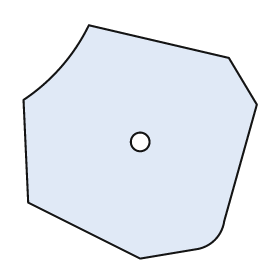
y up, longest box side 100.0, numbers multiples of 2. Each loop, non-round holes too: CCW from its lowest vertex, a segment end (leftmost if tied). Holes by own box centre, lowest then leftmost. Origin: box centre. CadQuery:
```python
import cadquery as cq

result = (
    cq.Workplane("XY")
    .moveTo(0.0, -50.0)
    .lineTo(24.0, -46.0)
    .threePointArc((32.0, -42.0), (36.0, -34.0))
    .lineTo(50.0, 16.0)
    .lineTo(38.0, 36.0)
    .lineTo(-22.0, 50.0)
    .threePointArc((-34.0, 32.0), (-50.0, 18.0))
    .lineTo(-48.0, -26.0)
    .close()
    .moveTo(0.0, 0.0)
    .circle(4.0)
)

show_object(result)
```